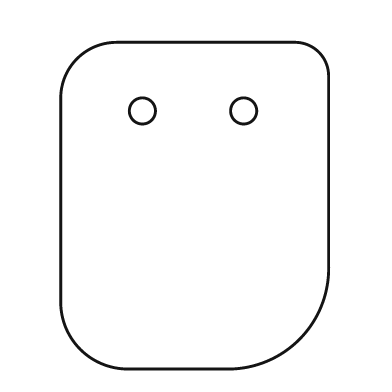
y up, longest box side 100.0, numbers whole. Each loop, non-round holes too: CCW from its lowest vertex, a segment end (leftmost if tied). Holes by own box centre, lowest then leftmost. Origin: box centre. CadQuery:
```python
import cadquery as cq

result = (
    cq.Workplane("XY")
    .moveTo(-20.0, -50.0)
    .lineTo(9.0, -50.0)
    .threePointArc((32.0, -41.0), (41.0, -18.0))
    .lineTo(41.0, 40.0)
    .threePointArc((38.0, 47.0), (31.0, 50.0))
    .lineTo(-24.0, 50.0)
    .threePointArc((-36.0, 45.0), (-41.0, 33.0))
    .lineTo(-41.0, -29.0)
    .threePointArc((-35.0, -44.0), (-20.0, -50.0))
    .close()
    .moveTo(-16.0, 29.0)
    .circle(4.0)
    .moveTo(15.0, 29.0)
    .circle(4.0)
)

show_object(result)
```